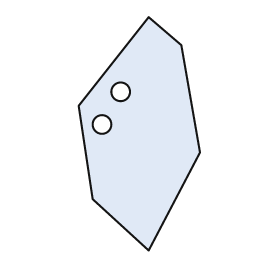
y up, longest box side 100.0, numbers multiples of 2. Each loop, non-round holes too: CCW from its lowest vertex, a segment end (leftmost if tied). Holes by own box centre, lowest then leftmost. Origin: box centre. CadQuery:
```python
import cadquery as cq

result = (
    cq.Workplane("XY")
    .moveTo(4.0, -50.0)
    .lineTo(26.0, -8.0)
    .lineTo(18.0, 38.0)
    .lineTo(4.0, 50.0)
    .lineTo(-26.0, 12.0)
    .lineTo(-20.0, -28.0)
    .close()
    .moveTo(-16.0, 4.0)
    .circle(4.0)
    .moveTo(-8.0, 18.0)
    .circle(4.0)
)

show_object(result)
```